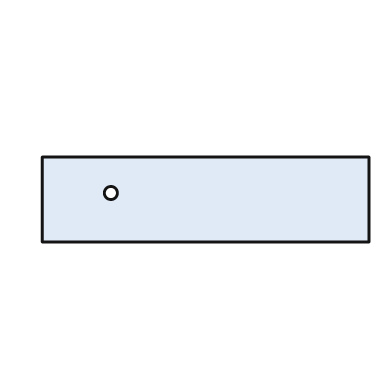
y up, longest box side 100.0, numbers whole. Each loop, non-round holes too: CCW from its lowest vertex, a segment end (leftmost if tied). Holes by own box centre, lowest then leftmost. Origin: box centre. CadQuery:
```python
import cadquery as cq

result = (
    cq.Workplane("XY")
    .moveTo(-50.0, -13.0)
    .lineTo(50.0, -13.0)
    .lineTo(50.0, 13.0)
    .lineTo(-50.0, 13.0)
    .close()
    .moveTo(-29.0, 2.0)
    .circle(2.0)
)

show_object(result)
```